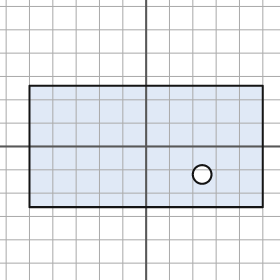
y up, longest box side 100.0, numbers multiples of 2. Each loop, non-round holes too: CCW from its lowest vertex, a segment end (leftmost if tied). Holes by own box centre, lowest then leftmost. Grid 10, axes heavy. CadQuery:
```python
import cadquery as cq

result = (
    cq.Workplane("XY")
    .moveTo(-50.0, -26.0)
    .lineTo(50.0, -26.0)
    .lineTo(50.0, 26.0)
    .lineTo(-50.0, 26.0)
    .close()
    .moveTo(24.0, -12.0)
    .circle(4.0)
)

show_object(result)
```